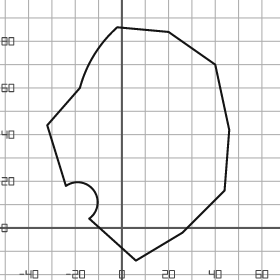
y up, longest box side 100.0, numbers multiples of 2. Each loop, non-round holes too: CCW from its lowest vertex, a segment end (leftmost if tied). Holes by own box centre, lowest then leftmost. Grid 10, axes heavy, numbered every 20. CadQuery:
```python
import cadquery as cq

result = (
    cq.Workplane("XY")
    .moveTo(6.0, -14.0)
    .lineTo(26.0, -2.0)
    .lineTo(44.0, 16.0)
    .lineTo(46.0, 42.0)
    .lineTo(40.0, 70.0)
    .lineTo(20.0, 84.0)
    .lineTo(-2.0, 86.0)
    .threePointArc((-12.0, 74.0), (-18.0, 60.0))
    .lineTo(-32.0, 44.0)
    .lineTo(-24.0, 18.0)
    .threePointArc((-12.0, 16.0), (-14.0, 4.0))
    .close()
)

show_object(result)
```